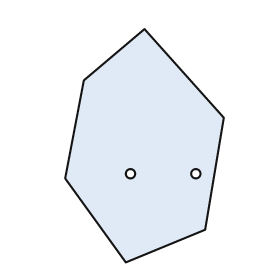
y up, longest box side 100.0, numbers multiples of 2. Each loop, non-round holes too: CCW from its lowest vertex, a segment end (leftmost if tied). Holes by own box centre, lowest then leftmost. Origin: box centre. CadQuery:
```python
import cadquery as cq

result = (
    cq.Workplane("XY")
    .moveTo(-8.0, -50.0)
    .lineTo(26.0, -36.0)
    .lineTo(34.0, 12.0)
    .lineTo(0.0, 50.0)
    .lineTo(-26.0, 28.0)
    .lineTo(-34.0, -14.0)
    .close()
    .moveTo(-6.0, -12.0)
    .circle(2.0)
    .moveTo(22.0, -12.0)
    .circle(2.0)
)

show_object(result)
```